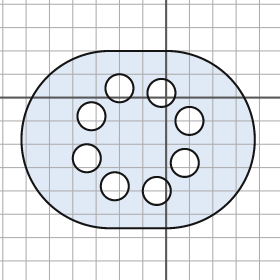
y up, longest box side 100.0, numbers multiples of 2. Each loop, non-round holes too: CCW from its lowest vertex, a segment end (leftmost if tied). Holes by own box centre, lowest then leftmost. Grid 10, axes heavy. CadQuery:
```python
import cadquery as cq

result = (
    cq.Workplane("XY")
    .moveTo(-24.0, -56.0)
    .lineTo(0.0, -56.0)
    .threePointArc((38.0, -18.0), (0.0, 20.0))
    .lineTo(-24.0, 20.0)
    .threePointArc((-62.0, -18.0), (-24.0, -56.0))
    .close()
    .moveTo(-4.0, -40.0)
    .circle(6.0)
    .moveTo(-22.0, -38.0)
    .circle(6.0)
    .moveTo(8.0, -28.0)
    .circle(6.0)
    .moveTo(-34.0, -26.0)
    .circle(6.0)
    .moveTo(10.0, -10.0)
    .circle(6.0)
    .moveTo(-32.0, -8.0)
    .circle(6.0)
    .moveTo(-2.0, 2.0)
    .circle(6.0)
    .moveTo(-20.0, 4.0)
    .circle(6.0)
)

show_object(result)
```